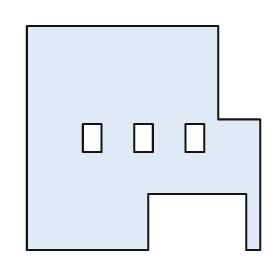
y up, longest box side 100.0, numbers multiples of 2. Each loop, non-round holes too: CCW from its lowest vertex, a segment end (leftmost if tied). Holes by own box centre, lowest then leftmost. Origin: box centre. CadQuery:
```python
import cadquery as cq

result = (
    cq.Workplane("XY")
    .moveTo(-50.0, -48.0)
    .lineTo(2.0, -48.0)
    .lineTo(2.0, -24.0)
    .lineTo(44.0, -24.0)
    .lineTo(44.0, -48.0)
    .lineTo(50.0, -48.0)
    .lineTo(50.0, 8.0)
    .lineTo(32.0, 8.0)
    .lineTo(32.0, 48.0)
    .lineTo(-50.0, 48.0)
    .close()
    .moveTo(-26.0, -6.0)
    .lineTo(-18.0, -6.0)
    .lineTo(-18.0, 6.0)
    .lineTo(-26.0, 6.0)
    .close()
    .moveTo(-4.0, -6.0)
    .lineTo(4.0, -6.0)
    .lineTo(4.0, 6.0)
    .lineTo(-4.0, 6.0)
    .close()
    .moveTo(18.0, -6.0)
    .lineTo(26.0, -6.0)
    .lineTo(26.0, 6.0)
    .lineTo(18.0, 6.0)
    .close()
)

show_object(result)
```